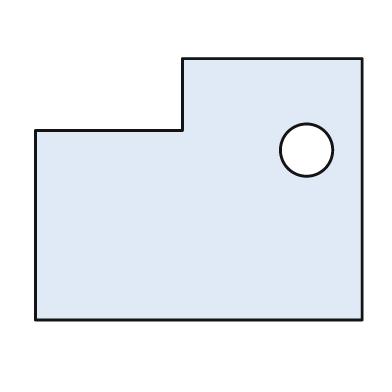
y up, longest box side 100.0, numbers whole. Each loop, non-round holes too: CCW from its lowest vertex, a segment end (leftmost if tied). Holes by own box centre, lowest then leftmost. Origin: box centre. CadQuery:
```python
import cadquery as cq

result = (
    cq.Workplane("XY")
    .moveTo(-50.0, -40.0)
    .lineTo(50.0, -40.0)
    .lineTo(50.0, 40.0)
    .lineTo(-5.0, 40.0)
    .lineTo(-5.0, 18.0)
    .lineTo(-50.0, 18.0)
    .close()
    .moveTo(33.0, 12.0)
    .circle(8.0)
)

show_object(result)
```